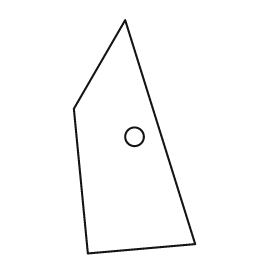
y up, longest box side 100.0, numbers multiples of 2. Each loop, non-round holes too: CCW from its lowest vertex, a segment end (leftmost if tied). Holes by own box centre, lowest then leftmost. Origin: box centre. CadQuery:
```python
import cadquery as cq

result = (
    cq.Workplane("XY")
    .moveTo(-20.0, -50.0)
    .lineTo(26.0, -46.0)
    .lineTo(-4.0, 50.0)
    .lineTo(-26.0, 12.0)
    .close()
    .moveTo(0.0, 0.0)
    .circle(4.0)
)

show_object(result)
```